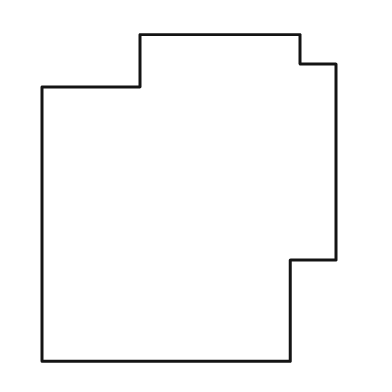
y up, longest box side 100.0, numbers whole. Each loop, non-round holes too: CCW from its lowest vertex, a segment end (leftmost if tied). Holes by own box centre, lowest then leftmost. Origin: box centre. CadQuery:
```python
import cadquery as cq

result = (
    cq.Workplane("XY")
    .moveTo(-45.0, -50.0)
    .lineTo(31.0, -50.0)
    .lineTo(31.0, -19.0)
    .lineTo(45.0, -19.0)
    .lineTo(45.0, 41.0)
    .lineTo(34.0, 41.0)
    .lineTo(34.0, 50.0)
    .lineTo(-15.0, 50.0)
    .lineTo(-15.0, 34.0)
    .lineTo(-45.0, 34.0)
    .close()
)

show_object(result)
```